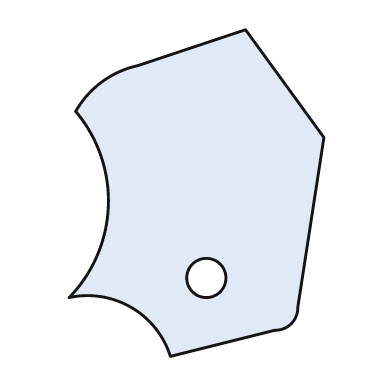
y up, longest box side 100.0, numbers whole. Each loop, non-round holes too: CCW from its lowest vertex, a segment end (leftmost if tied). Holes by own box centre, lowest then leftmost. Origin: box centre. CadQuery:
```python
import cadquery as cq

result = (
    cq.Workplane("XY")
    .moveTo(-8.0, -50.0)
    .lineTo(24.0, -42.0)
    .threePointArc((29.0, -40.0), (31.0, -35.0))
    .lineTo(39.0, 17.0)
    .lineTo(15.0, 50.0)
    .lineTo(-18.0, 39.0)
    .threePointArc((-29.0, 34.0), (-37.0, 25.0))
    .threePointArc((-27.0, -4.0), (-39.0, -32.0))
    .threePointArc((-20.0, -35.0), (-8.0, -50.0))
    .close()
    .moveTo(3.0, -26.0)
    .circle(6.0)
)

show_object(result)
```